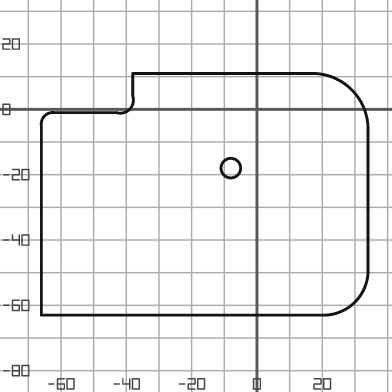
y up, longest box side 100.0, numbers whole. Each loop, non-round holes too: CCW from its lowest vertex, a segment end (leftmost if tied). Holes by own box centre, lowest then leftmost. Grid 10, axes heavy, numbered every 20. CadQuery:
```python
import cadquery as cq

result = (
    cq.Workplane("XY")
    .moveTo(-66.0, -63.0)
    .lineTo(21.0, -63.0)
    .threePointArc((30.0, -59.0), (34.0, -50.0))
    .lineTo(34.0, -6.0)
    .threePointArc((29.0, 6.0), (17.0, 11.0))
    .lineTo(-38.0, 11.0)
    .lineTo(-38.0, 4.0)
    .threePointArc((-39.0, 0.0), (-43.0, -1.0))
    .lineTo(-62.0, -1.0)
    .threePointArc((-65.0, -2.0), (-66.0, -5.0))
    .close()
    .moveTo(-8.0, -18.0)
    .circle(3.0)
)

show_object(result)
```